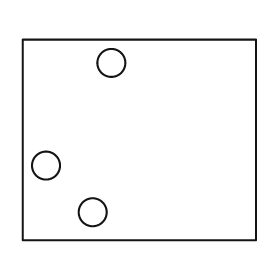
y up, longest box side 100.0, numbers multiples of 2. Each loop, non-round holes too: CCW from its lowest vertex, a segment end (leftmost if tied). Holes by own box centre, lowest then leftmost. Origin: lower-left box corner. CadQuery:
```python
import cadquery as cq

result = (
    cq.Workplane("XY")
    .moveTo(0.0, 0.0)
    .lineTo(100.0, 0.0)
    .lineTo(100.0, 86.0)
    .lineTo(0.0, 86.0)
    .close()
    .moveTo(30.0, 12.0)
    .circle(6.0)
    .moveTo(10.0, 32.0)
    .circle(6.0)
    .moveTo(38.0, 76.0)
    .circle(6.0)
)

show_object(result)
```